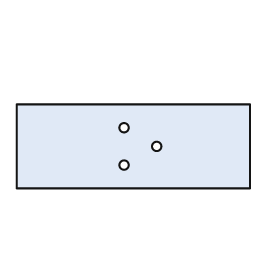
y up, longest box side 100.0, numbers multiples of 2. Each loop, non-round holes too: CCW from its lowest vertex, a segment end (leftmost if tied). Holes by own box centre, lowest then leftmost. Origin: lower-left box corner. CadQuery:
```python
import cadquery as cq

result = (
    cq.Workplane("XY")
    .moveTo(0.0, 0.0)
    .lineTo(100.0, 0.0)
    .lineTo(100.0, 36.0)
    .lineTo(0.0, 36.0)
    .close()
    .moveTo(46.0, 10.0)
    .circle(2.0)
    .moveTo(60.0, 18.0)
    .circle(2.0)
    .moveTo(46.0, 26.0)
    .circle(2.0)
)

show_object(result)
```